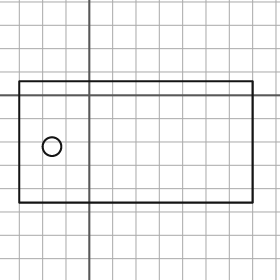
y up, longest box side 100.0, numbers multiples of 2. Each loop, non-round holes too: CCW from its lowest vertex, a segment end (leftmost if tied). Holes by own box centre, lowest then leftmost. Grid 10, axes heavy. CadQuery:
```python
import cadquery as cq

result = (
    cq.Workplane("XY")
    .moveTo(-30.0, -46.0)
    .lineTo(70.0, -46.0)
    .lineTo(70.0, 6.0)
    .lineTo(-30.0, 6.0)
    .close()
    .moveTo(-16.0, -22.0)
    .circle(4.0)
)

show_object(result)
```